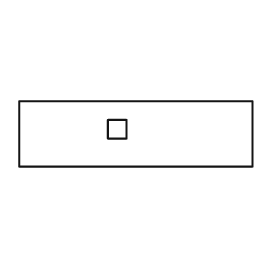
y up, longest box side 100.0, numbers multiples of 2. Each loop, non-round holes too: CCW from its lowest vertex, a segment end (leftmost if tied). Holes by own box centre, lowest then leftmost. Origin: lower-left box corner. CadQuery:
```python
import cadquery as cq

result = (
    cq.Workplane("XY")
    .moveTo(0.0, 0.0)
    .lineTo(100.0, 0.0)
    .lineTo(100.0, 28.0)
    .lineTo(0.0, 28.0)
    .close()
    .moveTo(38.0, 12.0)
    .lineTo(46.0, 12.0)
    .lineTo(46.0, 20.0)
    .lineTo(38.0, 20.0)
    .close()
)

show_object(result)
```